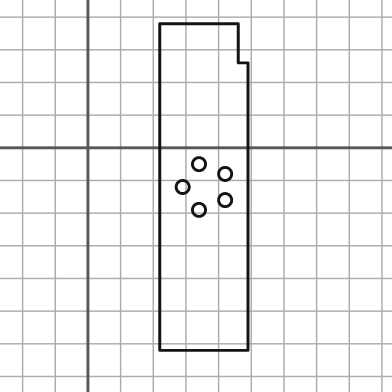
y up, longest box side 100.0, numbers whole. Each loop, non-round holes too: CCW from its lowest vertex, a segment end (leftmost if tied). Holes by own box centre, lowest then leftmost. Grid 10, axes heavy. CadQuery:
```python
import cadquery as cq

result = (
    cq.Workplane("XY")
    .moveTo(22.0, -62.0)
    .lineTo(49.0, -62.0)
    .lineTo(49.0, 26.0)
    .lineTo(46.0, 26.0)
    .lineTo(46.0, 38.0)
    .lineTo(22.0, 38.0)
    .close()
    .moveTo(34.0, -19.0)
    .circle(2.0)
    .moveTo(42.0, -16.0)
    .circle(2.0)
    .moveTo(29.0, -12.0)
    .circle(2.0)
    .moveTo(42.0, -8.0)
    .circle(2.0)
    .moveTo(34.0, -5.0)
    .circle(2.0)
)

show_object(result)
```